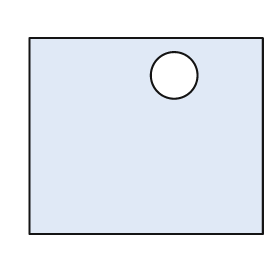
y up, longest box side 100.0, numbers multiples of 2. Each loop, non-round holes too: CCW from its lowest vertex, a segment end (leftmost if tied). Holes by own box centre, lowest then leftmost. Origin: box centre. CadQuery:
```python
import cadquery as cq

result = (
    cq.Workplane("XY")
    .moveTo(-50.0, -42.0)
    .lineTo(50.0, -42.0)
    .lineTo(50.0, 42.0)
    .lineTo(-50.0, 42.0)
    .close()
    .moveTo(12.0, 26.0)
    .circle(10.0)
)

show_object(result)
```